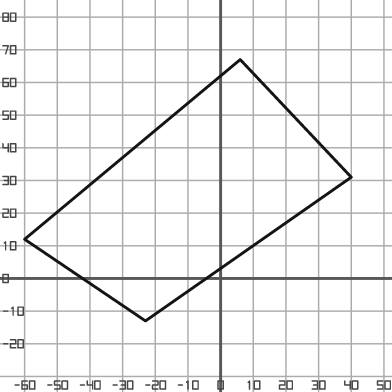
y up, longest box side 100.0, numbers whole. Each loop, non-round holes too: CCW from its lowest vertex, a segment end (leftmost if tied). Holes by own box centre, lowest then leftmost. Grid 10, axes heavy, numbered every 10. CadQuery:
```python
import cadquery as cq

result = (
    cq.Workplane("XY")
    .moveTo(-23.0, -13.0)
    .lineTo(40.0, 31.0)
    .lineTo(6.0, 67.0)
    .lineTo(-60.0, 12.0)
    .close()
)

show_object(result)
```